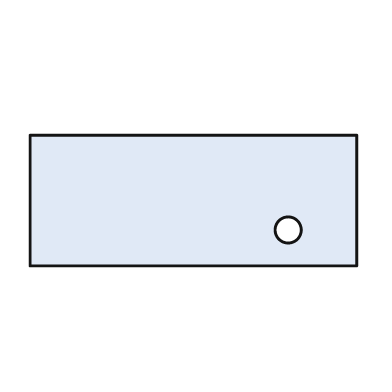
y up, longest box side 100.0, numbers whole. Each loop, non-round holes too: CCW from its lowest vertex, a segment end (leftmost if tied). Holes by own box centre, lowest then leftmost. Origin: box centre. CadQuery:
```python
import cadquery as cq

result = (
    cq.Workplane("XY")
    .moveTo(-50.0, -20.0)
    .lineTo(50.0, -20.0)
    .lineTo(50.0, 20.0)
    .lineTo(-50.0, 20.0)
    .close()
    .moveTo(29.0, -9.0)
    .circle(4.0)
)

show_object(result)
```